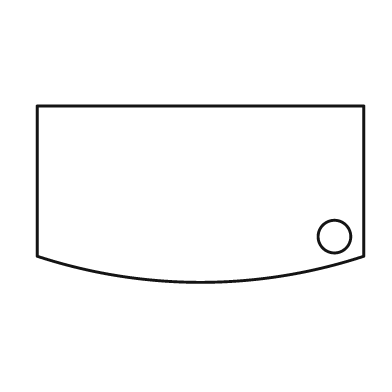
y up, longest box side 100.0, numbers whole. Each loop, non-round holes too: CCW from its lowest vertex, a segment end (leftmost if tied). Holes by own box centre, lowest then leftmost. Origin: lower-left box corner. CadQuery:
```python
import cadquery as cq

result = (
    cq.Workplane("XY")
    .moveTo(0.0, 8.0)
    .threePointArc((50.0, 0.0), (100.0, 8.0))
    .lineTo(100.0, 54.0)
    .lineTo(0.0, 54.0)
    .close()
    .moveTo(91.0, 14.0)
    .circle(5.0)
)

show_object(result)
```